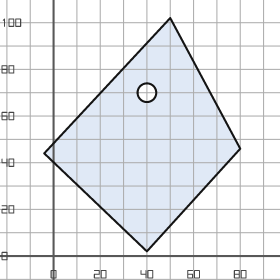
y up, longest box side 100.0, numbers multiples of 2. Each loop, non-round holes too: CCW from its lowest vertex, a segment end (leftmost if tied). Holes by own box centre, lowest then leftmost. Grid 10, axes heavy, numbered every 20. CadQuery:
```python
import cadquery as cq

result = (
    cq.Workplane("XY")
    .moveTo(40.0, 2.0)
    .lineTo(80.0, 46.0)
    .lineTo(50.0, 102.0)
    .lineTo(-4.0, 44.0)
    .close()
    .moveTo(40.0, 70.0)
    .circle(4.0)
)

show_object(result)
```